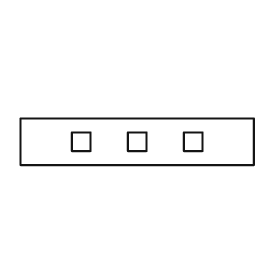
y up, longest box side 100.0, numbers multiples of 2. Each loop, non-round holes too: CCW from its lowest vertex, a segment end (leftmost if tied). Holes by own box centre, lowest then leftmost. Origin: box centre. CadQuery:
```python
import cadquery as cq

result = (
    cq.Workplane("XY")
    .moveTo(-50.0, -10.0)
    .lineTo(50.0, -10.0)
    .lineTo(50.0, 10.0)
    .lineTo(-50.0, 10.0)
    .close()
    .moveTo(-28.0, -4.0)
    .lineTo(-20.0, -4.0)
    .lineTo(-20.0, 4.0)
    .lineTo(-28.0, 4.0)
    .close()
    .moveTo(-4.0, -4.0)
    .lineTo(4.0, -4.0)
    .lineTo(4.0, 4.0)
    .lineTo(-4.0, 4.0)
    .close()
    .moveTo(20.0, -4.0)
    .lineTo(28.0, -4.0)
    .lineTo(28.0, 4.0)
    .lineTo(20.0, 4.0)
    .close()
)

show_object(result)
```